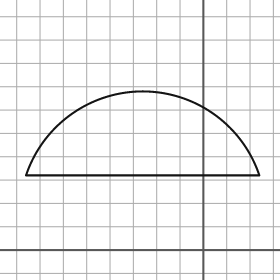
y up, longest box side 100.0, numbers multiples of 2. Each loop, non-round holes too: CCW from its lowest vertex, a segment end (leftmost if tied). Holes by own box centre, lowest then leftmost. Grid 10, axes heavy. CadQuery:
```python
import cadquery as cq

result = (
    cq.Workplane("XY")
    .moveTo(-76.0, 32.0)
    .lineTo(24.0, 32.0)
    .threePointArc((-26.0, 68.0), (-76.0, 32.0))
    .close()
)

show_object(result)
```